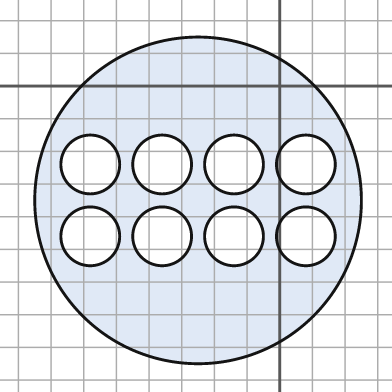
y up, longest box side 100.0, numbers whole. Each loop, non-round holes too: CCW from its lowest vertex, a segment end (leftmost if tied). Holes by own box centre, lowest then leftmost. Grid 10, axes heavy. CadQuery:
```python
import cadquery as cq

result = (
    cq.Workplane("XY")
    .moveTo(-25.0, -35.0)
    .circle(50.0)
    .moveTo(-58.0, -46.0)
    .circle(9.0)
    .moveTo(-36.0, -46.0)
    .circle(9.0)
    .moveTo(-14.0, -46.0)
    .circle(9.0)
    .moveTo(8.0, -46.0)
    .circle(9.0)
    .moveTo(-58.0, -24.0)
    .circle(9.0)
    .moveTo(-36.0, -24.0)
    .circle(9.0)
    .moveTo(-14.0, -24.0)
    .circle(9.0)
    .moveTo(8.0, -24.0)
    .circle(9.0)
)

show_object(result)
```